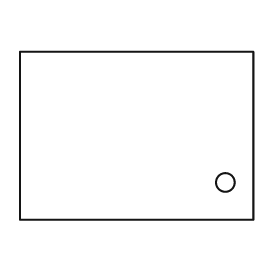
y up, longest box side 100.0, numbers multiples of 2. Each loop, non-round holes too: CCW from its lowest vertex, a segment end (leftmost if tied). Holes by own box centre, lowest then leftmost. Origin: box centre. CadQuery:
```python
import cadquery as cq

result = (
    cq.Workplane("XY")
    .moveTo(-50.0, -36.0)
    .lineTo(50.0, -36.0)
    .lineTo(50.0, 36.0)
    .lineTo(-50.0, 36.0)
    .close()
    .moveTo(38.0, -20.0)
    .circle(4.0)
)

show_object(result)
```